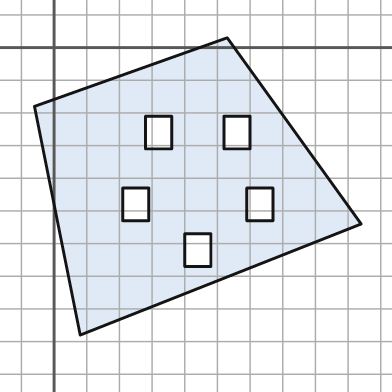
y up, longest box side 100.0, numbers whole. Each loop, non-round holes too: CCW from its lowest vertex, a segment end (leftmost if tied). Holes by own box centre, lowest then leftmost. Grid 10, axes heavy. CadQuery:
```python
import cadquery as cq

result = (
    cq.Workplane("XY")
    .moveTo(8.0, -88.0)
    .lineTo(94.0, -54.0)
    .lineTo(53.0, 3.0)
    .lineTo(-6.0, -18.0)
    .close()
    .moveTo(40.0, -67.0)
    .lineTo(48.0, -67.0)
    .lineTo(48.0, -57.0)
    .lineTo(40.0, -57.0)
    .close()
    .moveTo(21.0, -53.0)
    .lineTo(29.0, -53.0)
    .lineTo(29.0, -43.0)
    .lineTo(21.0, -43.0)
    .close()
    .moveTo(59.0, -53.0)
    .lineTo(67.0, -53.0)
    .lineTo(67.0, -43.0)
    .lineTo(59.0, -43.0)
    .close()
    .moveTo(28.0, -31.0)
    .lineTo(36.0, -31.0)
    .lineTo(36.0, -21.0)
    .lineTo(28.0, -21.0)
    .close()
    .moveTo(52.0, -31.0)
    .lineTo(60.0, -31.0)
    .lineTo(60.0, -21.0)
    .lineTo(52.0, -21.0)
    .close()
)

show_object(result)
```